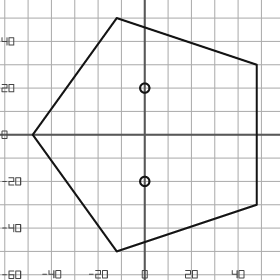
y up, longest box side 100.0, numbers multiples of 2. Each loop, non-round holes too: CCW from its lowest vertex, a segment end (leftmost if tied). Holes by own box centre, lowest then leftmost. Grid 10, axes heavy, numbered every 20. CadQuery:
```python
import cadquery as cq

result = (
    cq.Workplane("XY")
    .moveTo(-12.0, -50.0)
    .lineTo(48.0, -30.0)
    .lineTo(48.0, 30.0)
    .lineTo(-12.0, 50.0)
    .lineTo(-48.0, 0.0)
    .close()
    .moveTo(0.0, -20.0)
    .circle(2.0)
    .moveTo(0.0, 20.0)
    .circle(2.0)
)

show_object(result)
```